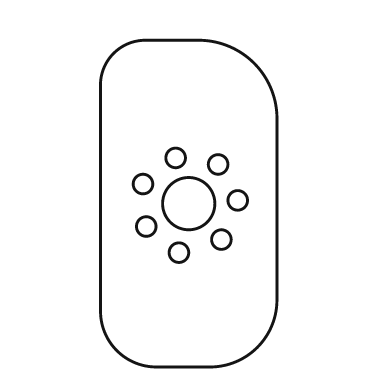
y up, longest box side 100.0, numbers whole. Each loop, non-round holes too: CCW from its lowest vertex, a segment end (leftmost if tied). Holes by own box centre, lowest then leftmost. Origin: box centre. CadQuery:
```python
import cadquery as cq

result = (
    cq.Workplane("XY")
    .moveTo(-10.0, -50.0)
    .lineTo(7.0, -50.0)
    .threePointArc((21.0, -44.0), (27.0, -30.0))
    .lineTo(27.0, 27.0)
    .threePointArc((20.0, 43.0), (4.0, 50.0))
    .lineTo(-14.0, 50.0)
    .threePointArc((-23.0, 46.0), (-27.0, 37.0))
    .lineTo(-27.0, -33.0)
    .threePointArc((-22.0, -45.0), (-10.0, -50.0))
    .close()
    .moveTo(-3.0, -15.0)
    .circle(3.0)
    .moveTo(10.0, -11.0)
    .circle(3.0)
    .moveTo(-13.0, -7.0)
    .circle(3.0)
    .moveTo(0.0, 0.0)
    .circle(8.0)
    .moveTo(15.0, 1.0)
    .circle(3.0)
    .moveTo(-14.0, 6.0)
    .circle(3.0)
    .moveTo(9.0, 12.0)
    .circle(3.0)
    .moveTo(-4.0, 14.0)
    .circle(3.0)
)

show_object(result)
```